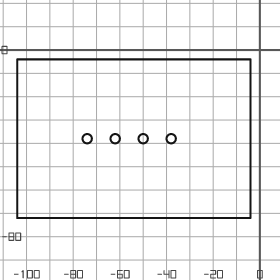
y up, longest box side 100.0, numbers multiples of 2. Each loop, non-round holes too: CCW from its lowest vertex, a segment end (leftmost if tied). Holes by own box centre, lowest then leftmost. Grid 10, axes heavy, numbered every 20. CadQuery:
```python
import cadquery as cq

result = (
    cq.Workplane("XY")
    .moveTo(-104.0, -72.0)
    .lineTo(-4.0, -72.0)
    .lineTo(-4.0, -4.0)
    .lineTo(-104.0, -4.0)
    .close()
    .moveTo(-74.0, -38.0)
    .circle(2.0)
    .moveTo(-62.0, -38.0)
    .circle(2.0)
    .moveTo(-50.0, -38.0)
    .circle(2.0)
    .moveTo(-38.0, -38.0)
    .circle(2.0)
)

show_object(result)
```